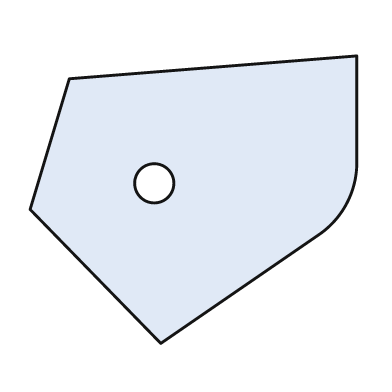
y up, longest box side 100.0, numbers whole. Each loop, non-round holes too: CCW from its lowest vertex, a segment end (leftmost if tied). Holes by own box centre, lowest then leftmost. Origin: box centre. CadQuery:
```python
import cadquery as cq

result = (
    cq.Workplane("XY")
    .moveTo(-10.0, -44.0)
    .lineTo(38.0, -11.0)
    .threePointArc((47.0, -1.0), (50.0, 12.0))
    .lineTo(50.0, 44.0)
    .lineTo(-38.0, 37.0)
    .lineTo(-50.0, -3.0)
    .close()
    .moveTo(-12.0, 5.0)
    .circle(6.0)
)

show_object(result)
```